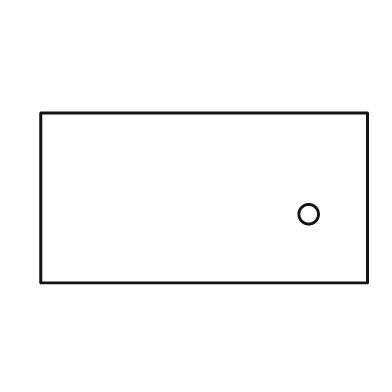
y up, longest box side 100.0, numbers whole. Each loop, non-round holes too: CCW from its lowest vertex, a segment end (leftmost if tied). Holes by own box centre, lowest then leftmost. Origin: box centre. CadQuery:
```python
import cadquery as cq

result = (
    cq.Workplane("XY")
    .moveTo(-50.0, -26.0)
    .lineTo(50.0, -26.0)
    .lineTo(50.0, 26.0)
    .lineTo(-50.0, 26.0)
    .close()
    .moveTo(32.0, -5.0)
    .circle(3.0)
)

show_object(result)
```